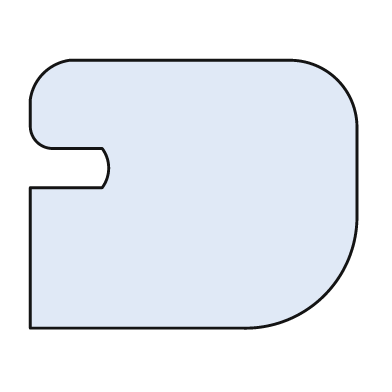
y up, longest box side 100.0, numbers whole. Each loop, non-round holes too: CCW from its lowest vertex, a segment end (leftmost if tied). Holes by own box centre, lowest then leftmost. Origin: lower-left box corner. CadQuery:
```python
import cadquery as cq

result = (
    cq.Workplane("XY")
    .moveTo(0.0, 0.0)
    .lineTo(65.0, 0.0)
    .threePointArc((90.0, 10.0), (100.0, 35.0))
    .lineTo(100.0, 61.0)
    .threePointArc((94.0, 76.0), (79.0, 82.0))
    .lineTo(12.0, 82.0)
    .threePointArc((4.0, 78.0), (0.0, 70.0))
    .lineTo(0.0, 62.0)
    .threePointArc((2.0, 57.0), (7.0, 55.0))
    .lineTo(22.0, 55.0)
    .threePointArc((24.0, 49.0), (22.0, 43.0))
    .lineTo(0.0, 43.0)
    .close()
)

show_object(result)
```